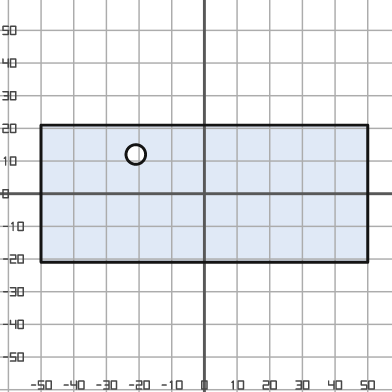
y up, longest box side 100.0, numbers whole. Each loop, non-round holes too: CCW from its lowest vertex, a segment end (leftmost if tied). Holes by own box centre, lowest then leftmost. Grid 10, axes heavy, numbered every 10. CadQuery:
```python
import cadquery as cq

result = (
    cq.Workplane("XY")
    .moveTo(-50.0, -21.0)
    .lineTo(50.0, -21.0)
    .lineTo(50.0, 21.0)
    .lineTo(-50.0, 21.0)
    .close()
    .moveTo(-21.0, 12.0)
    .circle(3.0)
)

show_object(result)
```